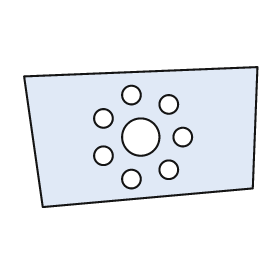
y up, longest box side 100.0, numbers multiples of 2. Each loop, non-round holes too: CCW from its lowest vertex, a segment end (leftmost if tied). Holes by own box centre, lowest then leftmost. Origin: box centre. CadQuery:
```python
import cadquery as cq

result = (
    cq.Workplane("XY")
    .moveTo(-42.0, -30.0)
    .lineTo(48.0, -22.0)
    .lineTo(50.0, 30.0)
    .lineTo(-50.0, 26.0)
    .close()
    .moveTo(-4.0, -18.0)
    .circle(4.0)
    .moveTo(12.0, -14.0)
    .circle(4.0)
    .moveTo(-16.0, -8.0)
    .circle(4.0)
    .moveTo(0.0, 0.0)
    .circle(8.0)
    .moveTo(18.0, 0.0)
    .circle(4.0)
    .moveTo(-16.0, 8.0)
    .circle(4.0)
    .moveTo(12.0, 14.0)
    .circle(4.0)
    .moveTo(-4.0, 18.0)
    .circle(4.0)
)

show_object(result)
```